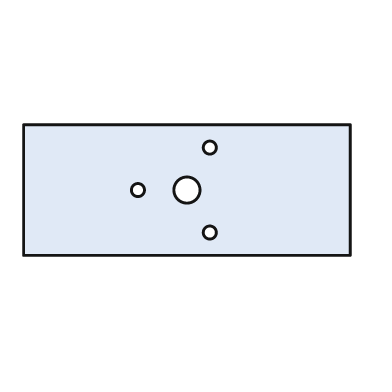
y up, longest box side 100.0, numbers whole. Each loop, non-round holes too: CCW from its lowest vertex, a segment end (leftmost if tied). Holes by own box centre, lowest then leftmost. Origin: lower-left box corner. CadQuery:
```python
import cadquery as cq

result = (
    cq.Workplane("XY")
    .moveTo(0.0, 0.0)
    .lineTo(100.0, 0.0)
    .lineTo(100.0, 40.0)
    .lineTo(0.0, 40.0)
    .close()
    .moveTo(57.0, 7.0)
    .circle(2.0)
    .moveTo(35.0, 20.0)
    .circle(2.0)
    .moveTo(50.0, 20.0)
    .circle(4.0)
    .moveTo(57.0, 33.0)
    .circle(2.0)
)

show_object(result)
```